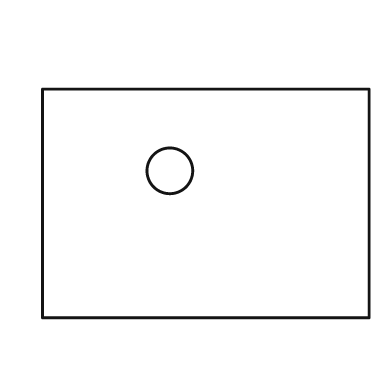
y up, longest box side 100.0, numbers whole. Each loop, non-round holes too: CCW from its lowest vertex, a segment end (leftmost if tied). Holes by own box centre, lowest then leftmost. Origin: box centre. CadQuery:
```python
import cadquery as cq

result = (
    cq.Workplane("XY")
    .moveTo(-50.0, -35.0)
    .lineTo(50.0, -35.0)
    .lineTo(50.0, 35.0)
    .lineTo(-50.0, 35.0)
    .close()
    .moveTo(-11.0, 10.0)
    .circle(7.0)
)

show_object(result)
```